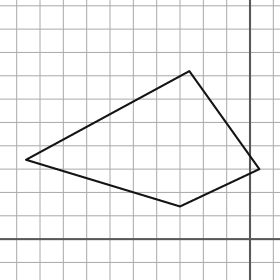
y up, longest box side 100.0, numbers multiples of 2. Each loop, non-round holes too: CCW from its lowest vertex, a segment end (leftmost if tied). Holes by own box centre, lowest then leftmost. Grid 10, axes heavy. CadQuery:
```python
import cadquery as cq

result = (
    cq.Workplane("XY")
    .moveTo(-30.0, 14.0)
    .lineTo(4.0, 30.0)
    .lineTo(-26.0, 72.0)
    .lineTo(-96.0, 34.0)
    .close()
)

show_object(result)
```